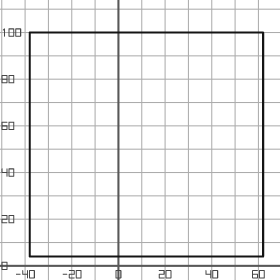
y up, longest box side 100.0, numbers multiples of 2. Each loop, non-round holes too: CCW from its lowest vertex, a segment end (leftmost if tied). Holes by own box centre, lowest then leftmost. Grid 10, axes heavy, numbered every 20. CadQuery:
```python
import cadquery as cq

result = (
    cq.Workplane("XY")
    .moveTo(-38.0, 4.0)
    .lineTo(62.0, 4.0)
    .lineTo(62.0, 100.0)
    .lineTo(-38.0, 100.0)
    .close()
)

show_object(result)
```